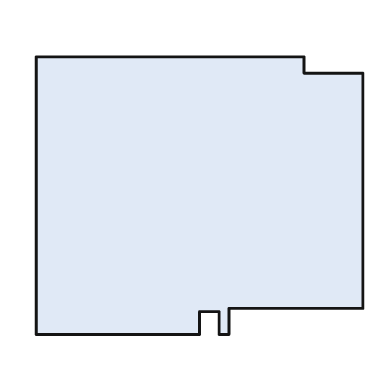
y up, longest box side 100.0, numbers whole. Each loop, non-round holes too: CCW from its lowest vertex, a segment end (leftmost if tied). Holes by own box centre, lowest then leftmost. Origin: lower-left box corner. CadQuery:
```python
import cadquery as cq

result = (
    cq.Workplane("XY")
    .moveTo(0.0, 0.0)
    .lineTo(50.0, 0.0)
    .lineTo(50.0, 7.0)
    .lineTo(56.0, 7.0)
    .lineTo(56.0, 0.0)
    .lineTo(59.0, 0.0)
    .lineTo(59.0, 8.0)
    .lineTo(100.0, 8.0)
    .lineTo(100.0, 80.0)
    .lineTo(82.0, 80.0)
    .lineTo(82.0, 85.0)
    .lineTo(0.0, 85.0)
    .close()
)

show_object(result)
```